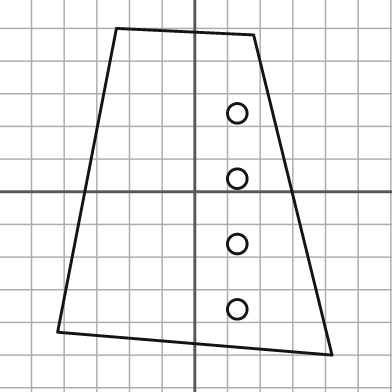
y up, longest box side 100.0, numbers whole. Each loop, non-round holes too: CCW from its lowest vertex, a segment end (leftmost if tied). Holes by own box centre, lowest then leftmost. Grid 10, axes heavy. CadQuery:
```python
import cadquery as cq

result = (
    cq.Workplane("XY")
    .moveTo(42.0, -50.0)
    .lineTo(18.0, 48.0)
    .lineTo(-24.0, 50.0)
    .lineTo(-42.0, -43.0)
    .close()
    .moveTo(13.0, -36.0)
    .circle(3.0)
    .moveTo(13.0, -16.0)
    .circle(3.0)
    .moveTo(13.0, 4.0)
    .circle(3.0)
    .moveTo(13.0, 24.0)
    .circle(3.0)
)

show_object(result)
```